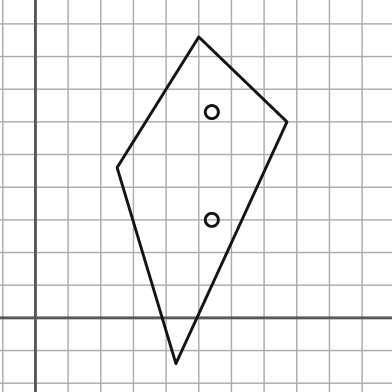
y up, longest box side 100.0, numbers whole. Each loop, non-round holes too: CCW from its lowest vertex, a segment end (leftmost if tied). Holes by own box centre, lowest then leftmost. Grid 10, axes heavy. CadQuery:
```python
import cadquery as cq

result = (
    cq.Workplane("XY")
    .moveTo(43.0, -14.0)
    .lineTo(77.0, 60.0)
    .lineTo(50.0, 86.0)
    .lineTo(25.0, 46.0)
    .close()
    .moveTo(54.0, 30.0)
    .circle(2.0)
    .moveTo(54.0, 63.0)
    .circle(2.0)
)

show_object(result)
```